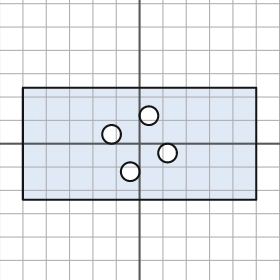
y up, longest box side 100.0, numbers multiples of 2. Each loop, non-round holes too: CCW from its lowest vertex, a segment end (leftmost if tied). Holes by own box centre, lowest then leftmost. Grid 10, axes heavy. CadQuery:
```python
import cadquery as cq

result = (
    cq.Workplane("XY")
    .moveTo(-50.0, -24.0)
    .lineTo(50.0, -24.0)
    .lineTo(50.0, 24.0)
    .lineTo(-50.0, 24.0)
    .close()
    .moveTo(-4.0, -12.0)
    .circle(4.0)
    .moveTo(12.0, -4.0)
    .circle(4.0)
    .moveTo(-12.0, 4.0)
    .circle(4.0)
    .moveTo(4.0, 12.0)
    .circle(4.0)
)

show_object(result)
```